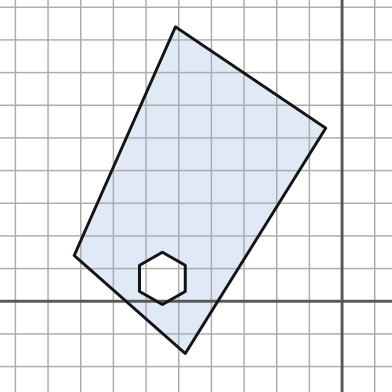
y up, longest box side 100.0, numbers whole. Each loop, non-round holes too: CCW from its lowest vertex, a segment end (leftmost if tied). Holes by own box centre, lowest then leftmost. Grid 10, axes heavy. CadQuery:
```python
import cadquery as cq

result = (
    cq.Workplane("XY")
    .moveTo(-48.0, -16.0)
    .lineTo(-5.0, 53.0)
    .lineTo(-51.0, 84.0)
    .lineTo(-82.0, 14.0)
    .close()
    .moveTo(-55.0, -1.0)
    .lineTo(-48.0, 3.0)
    .lineTo(-48.0, 11.0)
    .lineTo(-55.0, 15.0)
    .lineTo(-62.0, 11.0)
    .lineTo(-62.0, 3.0)
    .close()
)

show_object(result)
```